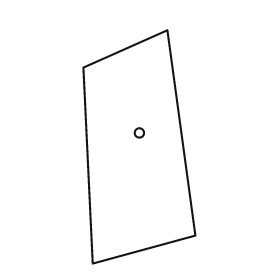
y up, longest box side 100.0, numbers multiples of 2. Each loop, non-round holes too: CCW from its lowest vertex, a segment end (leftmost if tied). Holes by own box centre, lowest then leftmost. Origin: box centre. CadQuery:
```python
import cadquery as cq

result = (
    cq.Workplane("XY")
    .moveTo(-20.0, -50.0)
    .lineTo(24.0, -38.0)
    .lineTo(12.0, 50.0)
    .lineTo(-24.0, 34.0)
    .close()
    .moveTo(0.0, 6.0)
    .circle(2.0)
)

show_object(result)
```